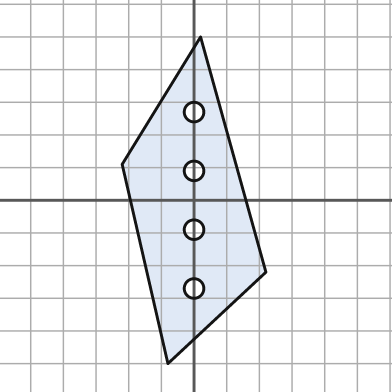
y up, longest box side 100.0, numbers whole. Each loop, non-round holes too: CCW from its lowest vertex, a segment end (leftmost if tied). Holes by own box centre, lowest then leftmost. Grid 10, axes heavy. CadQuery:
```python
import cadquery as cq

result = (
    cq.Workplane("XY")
    .moveTo(-8.0, -50.0)
    .lineTo(22.0, -22.0)
    .lineTo(2.0, 50.0)
    .lineTo(-22.0, 11.0)
    .close()
    .moveTo(0.0, -27.0)
    .circle(3.0)
    .moveTo(0.0, -9.0)
    .circle(3.0)
    .moveTo(0.0, 9.0)
    .circle(3.0)
    .moveTo(0.0, 27.0)
    .circle(3.0)
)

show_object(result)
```